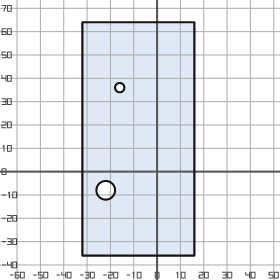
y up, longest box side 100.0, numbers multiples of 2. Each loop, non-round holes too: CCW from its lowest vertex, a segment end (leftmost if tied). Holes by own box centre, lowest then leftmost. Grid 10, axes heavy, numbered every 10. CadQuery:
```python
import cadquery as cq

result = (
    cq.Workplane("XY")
    .moveTo(-32.0, -36.0)
    .lineTo(16.0, -36.0)
    .lineTo(16.0, 64.0)
    .lineTo(-32.0, 64.0)
    .close()
    .moveTo(-22.0, -8.0)
    .circle(4.0)
    .moveTo(-16.0, 36.0)
    .circle(2.0)
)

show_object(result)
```